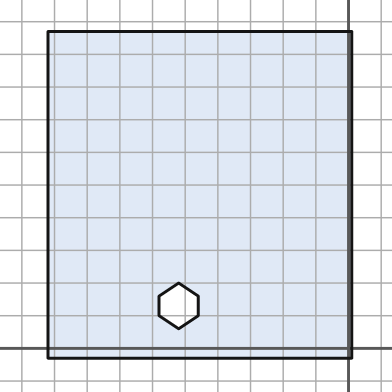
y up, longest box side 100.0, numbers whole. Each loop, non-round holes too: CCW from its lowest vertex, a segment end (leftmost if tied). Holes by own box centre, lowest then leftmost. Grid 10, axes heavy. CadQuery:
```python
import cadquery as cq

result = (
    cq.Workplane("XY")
    .moveTo(-92.0, -3.0)
    .lineTo(1.0, -3.0)
    .lineTo(1.0, 97.0)
    .lineTo(-92.0, 97.0)
    .close()
    .moveTo(-52.0, 6.0)
    .lineTo(-46.0, 10.0)
    .lineTo(-46.0, 16.0)
    .lineTo(-52.0, 20.0)
    .lineTo(-58.0, 16.0)
    .lineTo(-58.0, 10.0)
    .close()
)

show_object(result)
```